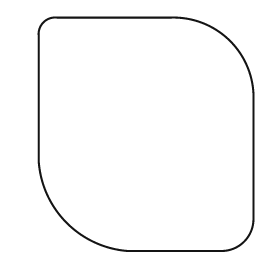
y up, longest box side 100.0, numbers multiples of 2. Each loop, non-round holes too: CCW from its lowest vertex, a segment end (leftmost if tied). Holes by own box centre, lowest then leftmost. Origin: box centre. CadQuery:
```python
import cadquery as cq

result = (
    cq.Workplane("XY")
    .moveTo(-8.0, -50.0)
    .lineTo(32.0, -50.0)
    .threePointArc((42.0, -46.0), (46.0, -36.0))
    .lineTo(46.0, 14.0)
    .threePointArc((36.0, 40.0), (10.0, 50.0))
    .lineTo(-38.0, 50.0)
    .threePointArc((-44.0, 48.0), (-46.0, 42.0))
    .lineTo(-46.0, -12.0)
    .threePointArc((-34.0, -38.0), (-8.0, -50.0))
    .close()
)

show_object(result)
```